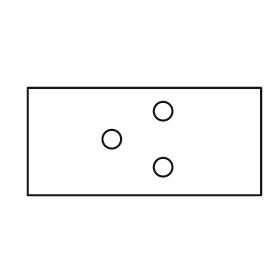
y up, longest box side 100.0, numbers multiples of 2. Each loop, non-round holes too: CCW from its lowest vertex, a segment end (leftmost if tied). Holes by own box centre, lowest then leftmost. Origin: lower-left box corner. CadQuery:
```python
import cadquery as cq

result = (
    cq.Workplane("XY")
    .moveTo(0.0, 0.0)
    .lineTo(100.0, 0.0)
    .lineTo(100.0, 46.0)
    .lineTo(0.0, 46.0)
    .close()
    .moveTo(58.0, 12.0)
    .circle(4.0)
    .moveTo(36.0, 24.0)
    .circle(4.0)
    .moveTo(58.0, 36.0)
    .circle(4.0)
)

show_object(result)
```